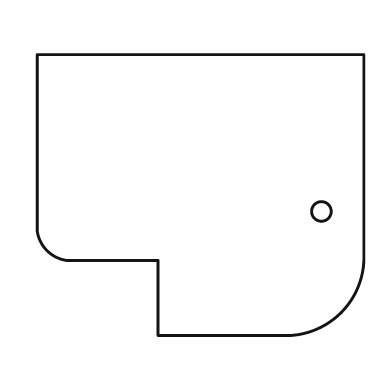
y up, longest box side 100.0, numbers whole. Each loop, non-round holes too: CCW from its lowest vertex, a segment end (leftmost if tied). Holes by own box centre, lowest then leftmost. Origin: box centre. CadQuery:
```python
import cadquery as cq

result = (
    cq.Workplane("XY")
    .moveTo(-13.0, -43.0)
    .lineTo(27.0, -43.0)
    .threePointArc((43.0, -36.0), (50.0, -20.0))
    .lineTo(50.0, 43.0)
    .lineTo(-50.0, 43.0)
    .lineTo(-50.0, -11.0)
    .threePointArc((-47.0, -17.0), (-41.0, -20.0))
    .lineTo(-13.0, -20.0)
    .close()
    .moveTo(37.0, -5.0)
    .circle(3.0)
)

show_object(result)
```